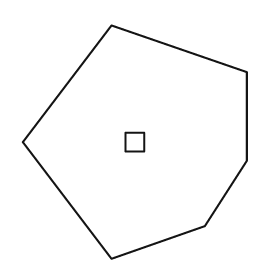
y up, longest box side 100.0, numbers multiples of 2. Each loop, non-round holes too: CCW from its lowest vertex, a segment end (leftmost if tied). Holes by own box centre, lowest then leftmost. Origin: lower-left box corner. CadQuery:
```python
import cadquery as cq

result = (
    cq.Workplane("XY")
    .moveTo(38.0, 0.0)
    .lineTo(78.0, 14.0)
    .lineTo(96.0, 42.0)
    .lineTo(96.0, 80.0)
    .lineTo(38.0, 100.0)
    .lineTo(0.0, 50.0)
    .close()
    .moveTo(44.0, 46.0)
    .lineTo(52.0, 46.0)
    .lineTo(52.0, 54.0)
    .lineTo(44.0, 54.0)
    .close()
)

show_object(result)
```